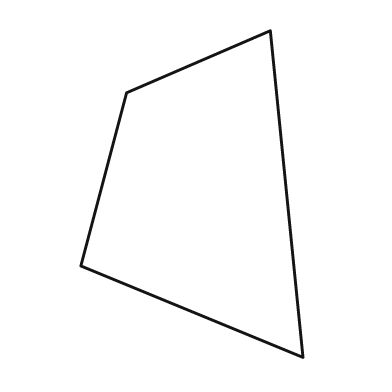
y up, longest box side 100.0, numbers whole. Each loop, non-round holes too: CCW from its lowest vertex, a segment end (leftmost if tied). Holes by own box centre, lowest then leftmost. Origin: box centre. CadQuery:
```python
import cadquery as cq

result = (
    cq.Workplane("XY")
    .moveTo(34.0, -50.0)
    .lineTo(24.0, 50.0)
    .lineTo(-20.0, 31.0)
    .lineTo(-34.0, -22.0)
    .close()
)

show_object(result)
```